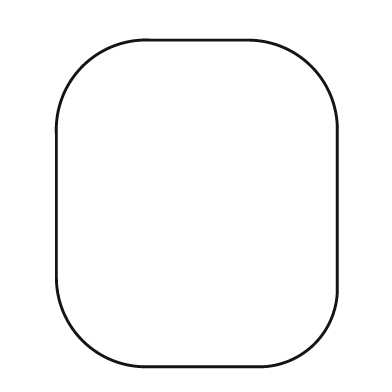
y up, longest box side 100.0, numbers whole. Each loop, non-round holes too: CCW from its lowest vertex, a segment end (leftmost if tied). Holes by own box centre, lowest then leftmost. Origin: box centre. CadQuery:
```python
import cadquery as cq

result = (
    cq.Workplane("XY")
    .moveTo(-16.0, -50.0)
    .lineTo(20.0, -50.0)
    .threePointArc((36.0, -43.0), (43.0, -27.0))
    .lineTo(43.0, 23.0)
    .threePointArc((35.0, 42.0), (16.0, 50.0))
    .lineTo(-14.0, 50.0)
    .threePointArc((-35.0, 42.0), (-43.0, 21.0))
    .lineTo(-43.0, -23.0)
    .threePointArc((-35.0, -42.0), (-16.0, -50.0))
    .close()
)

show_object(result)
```